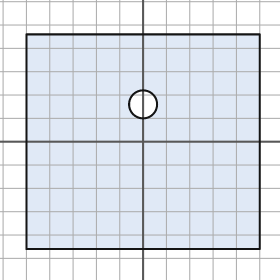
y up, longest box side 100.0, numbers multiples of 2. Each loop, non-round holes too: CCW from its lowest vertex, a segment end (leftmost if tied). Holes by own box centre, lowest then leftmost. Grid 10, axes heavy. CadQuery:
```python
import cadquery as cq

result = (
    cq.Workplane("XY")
    .moveTo(-50.0, -46.0)
    .lineTo(50.0, -46.0)
    .lineTo(50.0, 46.0)
    .lineTo(-50.0, 46.0)
    .close()
    .moveTo(0.0, 16.0)
    .circle(6.0)
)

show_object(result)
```